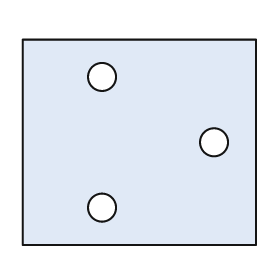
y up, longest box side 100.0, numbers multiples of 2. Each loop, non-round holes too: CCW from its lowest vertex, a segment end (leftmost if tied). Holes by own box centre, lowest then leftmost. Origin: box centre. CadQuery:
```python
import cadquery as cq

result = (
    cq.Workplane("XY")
    .moveTo(-50.0, -44.0)
    .lineTo(50.0, -44.0)
    .lineTo(50.0, 44.0)
    .lineTo(-50.0, 44.0)
    .close()
    .moveTo(-16.0, -28.0)
    .circle(6.0)
    .moveTo(32.0, 0.0)
    .circle(6.0)
    .moveTo(-16.0, 28.0)
    .circle(6.0)
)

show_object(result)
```